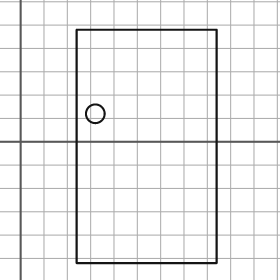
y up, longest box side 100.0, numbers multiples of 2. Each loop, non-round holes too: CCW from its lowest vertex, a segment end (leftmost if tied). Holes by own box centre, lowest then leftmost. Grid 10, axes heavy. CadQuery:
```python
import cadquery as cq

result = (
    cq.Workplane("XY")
    .moveTo(24.0, -52.0)
    .lineTo(84.0, -52.0)
    .lineTo(84.0, 48.0)
    .lineTo(24.0, 48.0)
    .close()
    .moveTo(32.0, 12.0)
    .circle(4.0)
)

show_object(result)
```